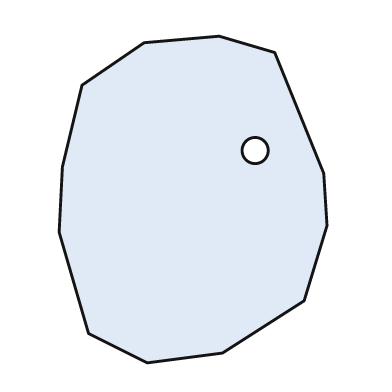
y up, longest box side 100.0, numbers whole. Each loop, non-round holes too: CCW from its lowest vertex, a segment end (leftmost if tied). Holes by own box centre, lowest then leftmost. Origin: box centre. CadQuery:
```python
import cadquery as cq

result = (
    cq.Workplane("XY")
    .moveTo(-14.0, -50.0)
    .lineTo(9.0, -47.0)
    .lineTo(34.0, -31.0)
    .lineTo(41.0, -8.0)
    .lineTo(40.0, 8.0)
    .lineTo(25.0, 45.0)
    .lineTo(8.0, 50.0)
    .lineTo(-15.0, 48.0)
    .lineTo(-34.0, 35.0)
    .lineTo(-40.0, 10.0)
    .lineTo(-41.0, -10.0)
    .lineTo(-32.0, -41.0)
    .close()
    .moveTo(19.0, 15.0)
    .circle(4.0)
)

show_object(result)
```